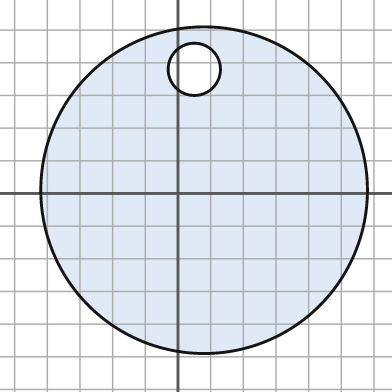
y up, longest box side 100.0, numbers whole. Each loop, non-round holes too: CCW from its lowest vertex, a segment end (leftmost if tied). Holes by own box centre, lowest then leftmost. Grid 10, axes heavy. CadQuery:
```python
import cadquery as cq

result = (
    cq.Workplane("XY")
    .moveTo(8.0, 1.0)
    .circle(50.0)
    .moveTo(5.0, 38.0)
    .circle(8.0)
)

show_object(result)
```